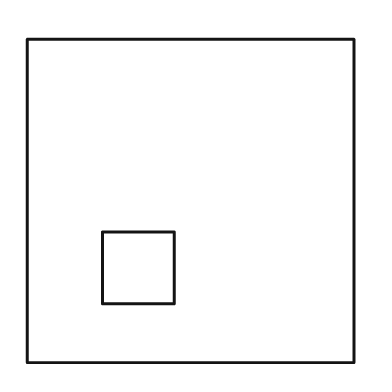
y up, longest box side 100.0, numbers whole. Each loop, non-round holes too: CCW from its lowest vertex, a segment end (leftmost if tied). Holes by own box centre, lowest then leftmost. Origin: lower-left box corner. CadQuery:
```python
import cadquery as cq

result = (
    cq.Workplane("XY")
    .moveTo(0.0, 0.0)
    .lineTo(100.0, 0.0)
    .lineTo(100.0, 99.0)
    .lineTo(0.0, 99.0)
    .close()
    .moveTo(23.0, 18.0)
    .lineTo(45.0, 18.0)
    .lineTo(45.0, 40.0)
    .lineTo(23.0, 40.0)
    .close()
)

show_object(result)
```